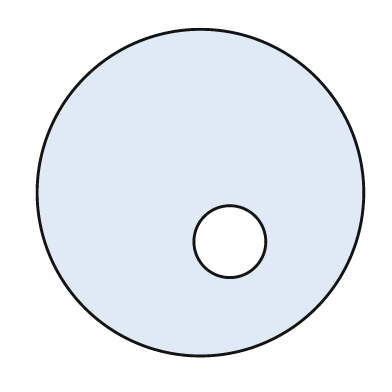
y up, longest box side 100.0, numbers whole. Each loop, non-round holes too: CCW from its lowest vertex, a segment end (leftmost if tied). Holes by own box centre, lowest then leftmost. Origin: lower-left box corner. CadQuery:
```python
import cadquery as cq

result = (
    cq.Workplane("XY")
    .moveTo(50.0, 50.0)
    .circle(50.0)
    .moveTo(59.0, 35.0)
    .circle(11.0)
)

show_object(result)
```